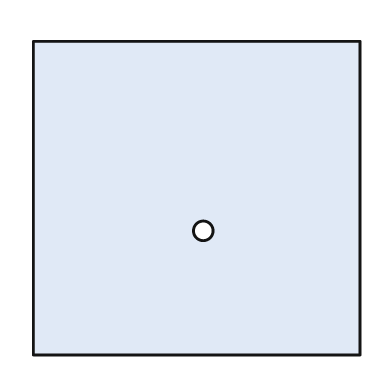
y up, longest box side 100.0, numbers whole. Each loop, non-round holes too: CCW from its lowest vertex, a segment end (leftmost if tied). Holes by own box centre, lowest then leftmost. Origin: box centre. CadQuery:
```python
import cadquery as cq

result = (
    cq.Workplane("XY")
    .moveTo(-50.0, -48.0)
    .lineTo(50.0, -48.0)
    .lineTo(50.0, 48.0)
    .lineTo(-50.0, 48.0)
    .close()
    .moveTo(2.0, -10.0)
    .circle(3.0)
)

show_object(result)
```